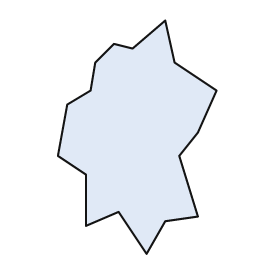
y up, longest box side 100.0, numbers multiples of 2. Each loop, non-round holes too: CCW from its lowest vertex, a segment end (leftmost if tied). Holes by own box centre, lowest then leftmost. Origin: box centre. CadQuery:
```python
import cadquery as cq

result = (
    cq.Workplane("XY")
    .moveTo(4.0, -50.0)
    .lineTo(12.0, -36.0)
    .lineTo(26.0, -34.0)
    .lineTo(18.0, -8.0)
    .lineTo(26.0, 2.0)
    .lineTo(34.0, 20.0)
    .lineTo(16.0, 32.0)
    .lineTo(12.0, 50.0)
    .lineTo(-2.0, 38.0)
    .lineTo(-10.0, 40.0)
    .lineTo(-18.0, 32.0)
    .lineTo(-20.0, 20.0)
    .lineTo(-30.0, 14.0)
    .lineTo(-34.0, -8.0)
    .lineTo(-22.0, -16.0)
    .lineTo(-22.0, -38.0)
    .lineTo(-8.0, -32.0)
    .close()
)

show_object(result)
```